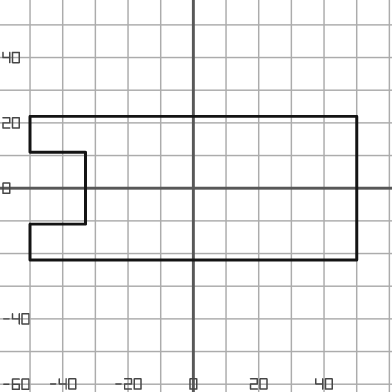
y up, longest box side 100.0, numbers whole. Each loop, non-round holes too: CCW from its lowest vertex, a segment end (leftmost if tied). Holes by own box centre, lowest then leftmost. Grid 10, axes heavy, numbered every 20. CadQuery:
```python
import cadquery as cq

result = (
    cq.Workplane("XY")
    .moveTo(-50.0, -22.0)
    .lineTo(50.0, -22.0)
    .lineTo(50.0, 22.0)
    .lineTo(-50.0, 22.0)
    .lineTo(-50.0, 11.0)
    .lineTo(-33.0, 11.0)
    .lineTo(-33.0, -11.0)
    .lineTo(-50.0, -11.0)
    .close()
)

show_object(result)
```